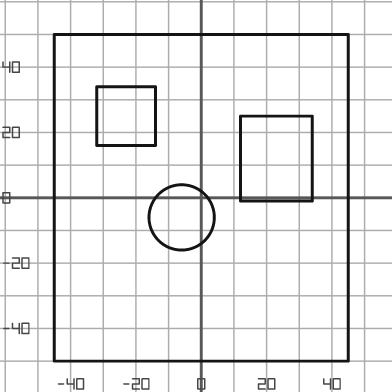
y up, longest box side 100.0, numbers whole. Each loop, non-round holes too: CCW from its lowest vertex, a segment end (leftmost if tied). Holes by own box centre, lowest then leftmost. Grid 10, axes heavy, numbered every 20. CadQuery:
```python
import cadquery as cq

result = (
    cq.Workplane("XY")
    .moveTo(-45.0, -50.0)
    .lineTo(45.0, -50.0)
    .lineTo(45.0, 50.0)
    .lineTo(-45.0, 50.0)
    .close()
    .moveTo(-6.0, -6.0)
    .circle(10.0)
    .moveTo(12.0, -1.0)
    .lineTo(34.0, -1.0)
    .lineTo(34.0, 25.0)
    .lineTo(12.0, 25.0)
    .close()
    .moveTo(-32.0, 16.0)
    .lineTo(-14.0, 16.0)
    .lineTo(-14.0, 34.0)
    .lineTo(-32.0, 34.0)
    .close()
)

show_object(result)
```